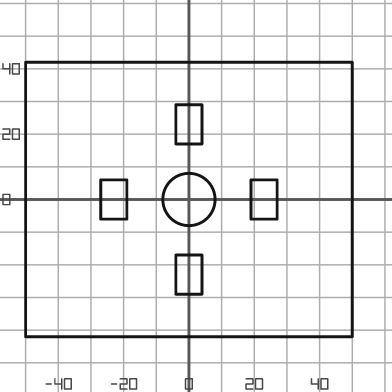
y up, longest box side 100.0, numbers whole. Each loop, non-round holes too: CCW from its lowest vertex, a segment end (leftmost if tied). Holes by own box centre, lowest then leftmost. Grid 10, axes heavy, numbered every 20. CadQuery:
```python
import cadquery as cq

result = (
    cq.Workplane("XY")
    .moveTo(-50.0, -42.0)
    .lineTo(50.0, -42.0)
    .lineTo(50.0, 42.0)
    .lineTo(-50.0, 42.0)
    .close()
    .moveTo(-4.0, -29.0)
    .lineTo(4.0, -29.0)
    .lineTo(4.0, -17.0)
    .lineTo(-4.0, -17.0)
    .close()
    .moveTo(-27.0, -6.0)
    .lineTo(-19.0, -6.0)
    .lineTo(-19.0, 6.0)
    .lineTo(-27.0, 6.0)
    .close()
    .moveTo(0.0, 0.0)
    .circle(8.0)
    .moveTo(19.0, -6.0)
    .lineTo(27.0, -6.0)
    .lineTo(27.0, 6.0)
    .lineTo(19.0, 6.0)
    .close()
    .moveTo(-4.0, 17.0)
    .lineTo(4.0, 17.0)
    .lineTo(4.0, 29.0)
    .lineTo(-4.0, 29.0)
    .close()
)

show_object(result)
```